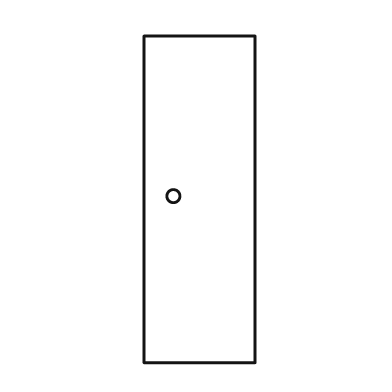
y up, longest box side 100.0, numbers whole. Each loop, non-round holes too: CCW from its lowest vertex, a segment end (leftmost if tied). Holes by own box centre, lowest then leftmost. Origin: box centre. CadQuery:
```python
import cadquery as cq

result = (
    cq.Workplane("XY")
    .moveTo(-17.0, -50.0)
    .lineTo(17.0, -50.0)
    .lineTo(17.0, 50.0)
    .lineTo(-17.0, 50.0)
    .close()
    .moveTo(-8.0, 1.0)
    .circle(2.0)
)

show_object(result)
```